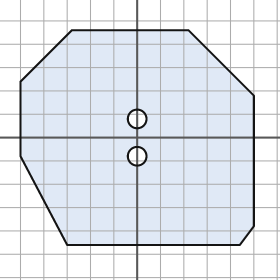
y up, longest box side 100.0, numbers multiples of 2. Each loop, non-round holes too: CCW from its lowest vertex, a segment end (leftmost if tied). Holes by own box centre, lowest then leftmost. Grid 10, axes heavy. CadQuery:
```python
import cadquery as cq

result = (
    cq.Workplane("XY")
    .moveTo(-30.0, -46.0)
    .lineTo(44.0, -46.0)
    .lineTo(50.0, -38.0)
    .lineTo(50.0, 18.0)
    .lineTo(22.0, 46.0)
    .lineTo(-28.0, 46.0)
    .lineTo(-50.0, 24.0)
    .lineTo(-50.0, -8.0)
    .close()
    .moveTo(0.0, -8.0)
    .circle(4.0)
    .moveTo(0.0, 8.0)
    .circle(4.0)
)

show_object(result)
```